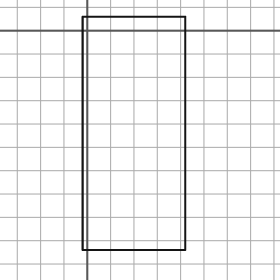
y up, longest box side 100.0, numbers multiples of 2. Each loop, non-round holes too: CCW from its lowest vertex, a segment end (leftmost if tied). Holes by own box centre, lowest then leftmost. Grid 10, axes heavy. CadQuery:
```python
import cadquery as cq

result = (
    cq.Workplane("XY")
    .moveTo(-2.0, -94.0)
    .lineTo(42.0, -94.0)
    .lineTo(42.0, 6.0)
    .lineTo(-2.0, 6.0)
    .close()
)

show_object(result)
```